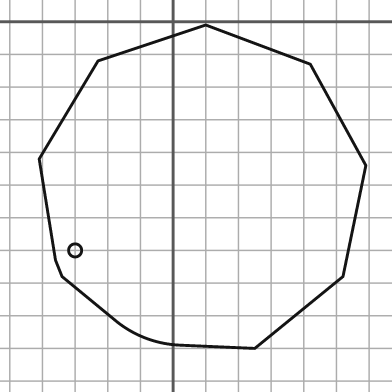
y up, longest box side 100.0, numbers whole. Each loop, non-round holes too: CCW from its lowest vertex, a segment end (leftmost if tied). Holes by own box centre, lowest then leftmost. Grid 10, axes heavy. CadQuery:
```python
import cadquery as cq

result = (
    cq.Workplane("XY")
    .moveTo(25.0, -100.0)
    .lineTo(52.0, -78.0)
    .lineTo(59.0, -44.0)
    .lineTo(42.0, -13.0)
    .lineTo(10.0, -1.0)
    .lineTo(-23.0, -12.0)
    .lineTo(-41.0, -42.0)
    .lineTo(-36.0, -73.0)
    .lineTo(-34.0, -78.0)
    .lineTo(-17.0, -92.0)
    .threePointArc((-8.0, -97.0), (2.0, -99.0))
    .close()
    .moveTo(-30.0, -70.0)
    .circle(2.0)
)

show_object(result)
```